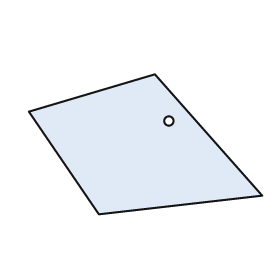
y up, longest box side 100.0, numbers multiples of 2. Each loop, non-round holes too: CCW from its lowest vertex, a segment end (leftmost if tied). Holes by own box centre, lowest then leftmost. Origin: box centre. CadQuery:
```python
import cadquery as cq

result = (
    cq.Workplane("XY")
    .moveTo(-20.0, -30.0)
    .lineTo(50.0, -22.0)
    .lineTo(4.0, 30.0)
    .lineTo(-50.0, 14.0)
    .close()
    .moveTo(10.0, 10.0)
    .circle(2.0)
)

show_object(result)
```